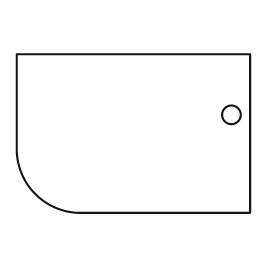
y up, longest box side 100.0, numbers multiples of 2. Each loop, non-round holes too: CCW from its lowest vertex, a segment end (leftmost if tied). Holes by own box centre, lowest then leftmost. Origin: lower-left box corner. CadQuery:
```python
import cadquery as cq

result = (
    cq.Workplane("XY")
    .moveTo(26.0, 0.0)
    .lineTo(100.0, 0.0)
    .lineTo(100.0, 68.0)
    .lineTo(0.0, 68.0)
    .lineTo(0.0, 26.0)
    .threePointArc((8.0, 8.0), (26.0, 0.0))
    .close()
    .moveTo(92.0, 42.0)
    .circle(4.0)
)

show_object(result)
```